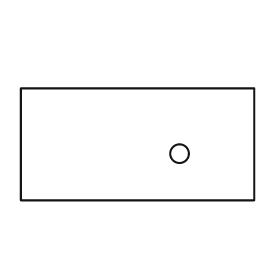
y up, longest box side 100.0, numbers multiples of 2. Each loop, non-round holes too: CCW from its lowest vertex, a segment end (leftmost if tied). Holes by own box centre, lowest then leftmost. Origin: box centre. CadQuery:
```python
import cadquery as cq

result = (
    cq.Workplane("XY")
    .moveTo(-50.0, -24.0)
    .lineTo(50.0, -24.0)
    .lineTo(50.0, 24.0)
    .lineTo(-50.0, 24.0)
    .close()
    .moveTo(18.0, -4.0)
    .circle(4.0)
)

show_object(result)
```